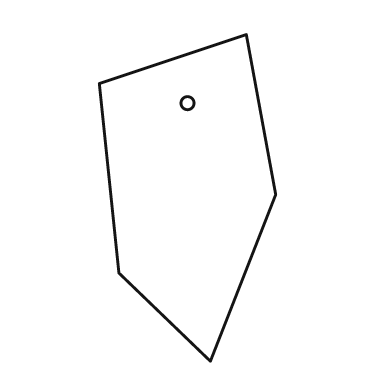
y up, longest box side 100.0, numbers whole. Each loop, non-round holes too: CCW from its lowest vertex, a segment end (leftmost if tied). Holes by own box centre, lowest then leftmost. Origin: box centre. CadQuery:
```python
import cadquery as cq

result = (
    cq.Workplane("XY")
    .moveTo(7.0, -50.0)
    .lineTo(27.0, 1.0)
    .lineTo(18.0, 50.0)
    .lineTo(-27.0, 35.0)
    .lineTo(-21.0, -23.0)
    .close()
    .moveTo(0.0, 29.0)
    .circle(2.0)
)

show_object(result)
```